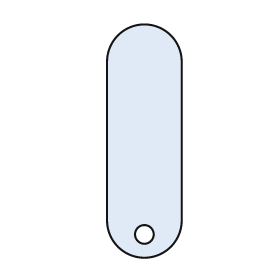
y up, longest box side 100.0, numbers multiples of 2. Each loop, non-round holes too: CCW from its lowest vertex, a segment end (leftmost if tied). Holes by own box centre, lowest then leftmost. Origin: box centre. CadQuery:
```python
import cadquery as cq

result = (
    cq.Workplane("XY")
    .moveTo(-16.0, -34.0)
    .threePointArc((0.0, -50.0), (16.0, -34.0))
    .lineTo(16.0, 34.0)
    .threePointArc((0.0, 50.0), (-16.0, 34.0))
    .close()
    .moveTo(0.0, -40.0)
    .circle(4.0)
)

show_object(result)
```